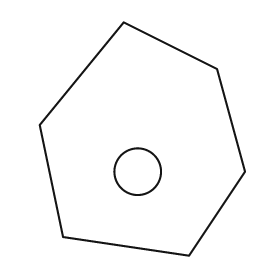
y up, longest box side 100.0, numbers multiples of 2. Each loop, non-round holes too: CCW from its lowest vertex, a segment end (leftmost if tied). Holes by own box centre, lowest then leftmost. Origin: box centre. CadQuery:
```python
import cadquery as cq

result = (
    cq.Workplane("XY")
    .moveTo(20.0, -50.0)
    .lineTo(44.0, -14.0)
    .lineTo(32.0, 30.0)
    .lineTo(-8.0, 50.0)
    .lineTo(-44.0, 6.0)
    .lineTo(-34.0, -42.0)
    .close()
    .moveTo(-2.0, -14.0)
    .circle(10.0)
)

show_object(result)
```